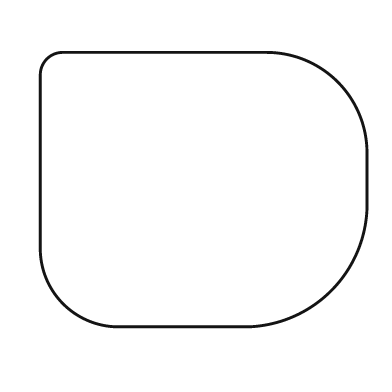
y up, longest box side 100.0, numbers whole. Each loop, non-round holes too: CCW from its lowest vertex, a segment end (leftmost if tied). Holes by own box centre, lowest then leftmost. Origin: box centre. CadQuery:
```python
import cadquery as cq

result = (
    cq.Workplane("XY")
    .moveTo(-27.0, -42.0)
    .lineTo(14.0, -42.0)
    .threePointArc((39.0, -31.0), (50.0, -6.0))
    .lineTo(50.0, 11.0)
    .threePointArc((41.0, 33.0), (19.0, 42.0))
    .lineTo(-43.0, 42.0)
    .threePointArc((-48.0, 40.0), (-50.0, 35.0))
    .lineTo(-50.0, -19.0)
    .threePointArc((-43.0, -35.0), (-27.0, -42.0))
    .close()
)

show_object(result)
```